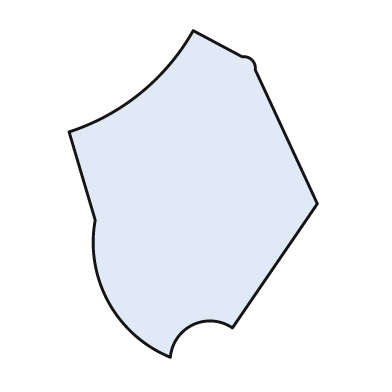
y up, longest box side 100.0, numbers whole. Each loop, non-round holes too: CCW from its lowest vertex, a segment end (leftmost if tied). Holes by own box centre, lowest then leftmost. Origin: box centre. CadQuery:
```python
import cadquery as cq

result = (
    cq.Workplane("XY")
    .moveTo(-7.0, -50.0)
    .threePointArc((0.0, -40.0), (12.0, -41.0))
    .lineTo(38.0, -3.0)
    .lineTo(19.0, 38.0)
    .threePointArc((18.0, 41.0), (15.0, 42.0))
    .lineTo(0.0, 50.0)
    .threePointArc((-16.0, 31.0), (-38.0, 19.0))
    .lineTo(-30.0, -8.0)
    .threePointArc((-26.0, -33.0), (-7.0, -50.0))
    .close()
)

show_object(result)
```